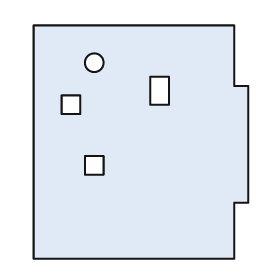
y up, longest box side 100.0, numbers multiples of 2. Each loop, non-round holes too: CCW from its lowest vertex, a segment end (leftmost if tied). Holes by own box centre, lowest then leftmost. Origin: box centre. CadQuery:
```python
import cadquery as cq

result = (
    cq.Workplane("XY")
    .moveTo(-46.0, -50.0)
    .lineTo(40.0, -50.0)
    .lineTo(40.0, -26.0)
    .lineTo(46.0, -26.0)
    .lineTo(46.0, 24.0)
    .lineTo(40.0, 24.0)
    .lineTo(40.0, 50.0)
    .lineTo(-46.0, 50.0)
    .close()
    .moveTo(-24.0, -14.0)
    .lineTo(-16.0, -14.0)
    .lineTo(-16.0, -6.0)
    .lineTo(-24.0, -6.0)
    .close()
    .moveTo(-34.0, 12.0)
    .lineTo(-26.0, 12.0)
    .lineTo(-26.0, 20.0)
    .lineTo(-34.0, 20.0)
    .close()
    .moveTo(4.0, 16.0)
    .lineTo(12.0, 16.0)
    .lineTo(12.0, 28.0)
    .lineTo(4.0, 28.0)
    .close()
    .moveTo(-20.0, 34.0)
    .circle(4.0)
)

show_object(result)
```